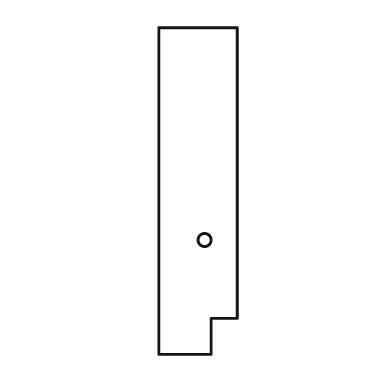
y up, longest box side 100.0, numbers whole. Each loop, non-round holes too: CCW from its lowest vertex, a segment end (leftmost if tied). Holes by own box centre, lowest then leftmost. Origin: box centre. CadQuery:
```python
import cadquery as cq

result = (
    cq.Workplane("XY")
    .moveTo(-12.0, -50.0)
    .lineTo(4.0, -50.0)
    .lineTo(4.0, -39.0)
    .lineTo(12.0, -39.0)
    .lineTo(12.0, 50.0)
    .lineTo(-12.0, 50.0)
    .close()
    .moveTo(2.0, -15.0)
    .circle(2.0)
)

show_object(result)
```